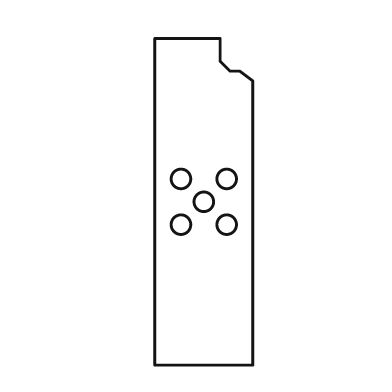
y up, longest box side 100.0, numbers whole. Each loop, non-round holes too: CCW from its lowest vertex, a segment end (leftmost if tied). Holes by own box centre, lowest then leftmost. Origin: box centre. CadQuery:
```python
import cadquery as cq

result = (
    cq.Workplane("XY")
    .moveTo(-15.0, -50.0)
    .lineTo(15.0, -50.0)
    .lineTo(15.0, 37.0)
    .lineTo(11.0, 40.0)
    .lineTo(8.0, 40.0)
    .lineTo(5.0, 43.0)
    .lineTo(5.0, 50.0)
    .lineTo(-15.0, 50.0)
    .close()
    .moveTo(-7.0, -7.0)
    .circle(3.0)
    .moveTo(7.0, -7.0)
    .circle(3.0)
    .moveTo(0.0, 0.0)
    .circle(3.0)
    .moveTo(-7.0, 7.0)
    .circle(3.0)
    .moveTo(7.0, 7.0)
    .circle(3.0)
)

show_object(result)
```